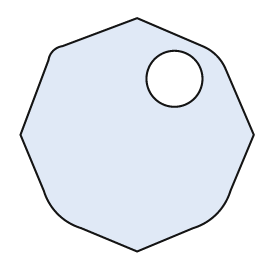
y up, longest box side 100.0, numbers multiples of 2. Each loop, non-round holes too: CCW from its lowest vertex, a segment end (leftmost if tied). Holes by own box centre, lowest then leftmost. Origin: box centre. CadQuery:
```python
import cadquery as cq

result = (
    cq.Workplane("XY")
    .moveTo(0.0, -50.0)
    .lineTo(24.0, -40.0)
    .threePointArc((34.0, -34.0), (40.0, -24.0))
    .lineTo(50.0, 0.0)
    .lineTo(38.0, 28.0)
    .threePointArc((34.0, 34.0), (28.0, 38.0))
    .lineTo(0.0, 50.0)
    .lineTo(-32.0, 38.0)
    .threePointArc((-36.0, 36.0), (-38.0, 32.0))
    .lineTo(-50.0, 0.0)
    .lineTo(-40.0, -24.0)
    .threePointArc((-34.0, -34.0), (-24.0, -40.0))
    .close()
    .moveTo(16.0, 24.0)
    .circle(12.0)
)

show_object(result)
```